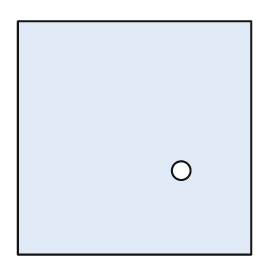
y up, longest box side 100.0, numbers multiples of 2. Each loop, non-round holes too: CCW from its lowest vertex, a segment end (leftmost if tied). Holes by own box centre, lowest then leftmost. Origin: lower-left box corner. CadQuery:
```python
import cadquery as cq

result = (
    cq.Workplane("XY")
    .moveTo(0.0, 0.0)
    .lineTo(100.0, 0.0)
    .lineTo(100.0, 100.0)
    .lineTo(0.0, 100.0)
    .close()
    .moveTo(70.0, 36.0)
    .circle(4.0)
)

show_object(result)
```